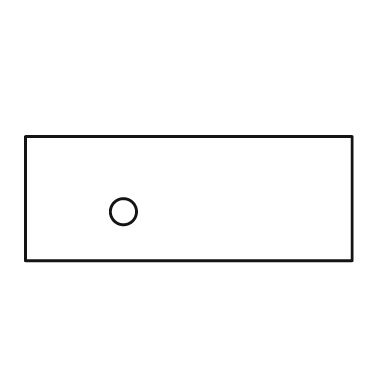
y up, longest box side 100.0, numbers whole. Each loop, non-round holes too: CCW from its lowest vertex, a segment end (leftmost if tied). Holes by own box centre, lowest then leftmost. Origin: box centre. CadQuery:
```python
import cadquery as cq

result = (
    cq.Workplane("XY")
    .moveTo(-50.0, -19.0)
    .lineTo(50.0, -19.0)
    .lineTo(50.0, 19.0)
    .lineTo(-50.0, 19.0)
    .close()
    .moveTo(-20.0, -4.0)
    .circle(4.0)
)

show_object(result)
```